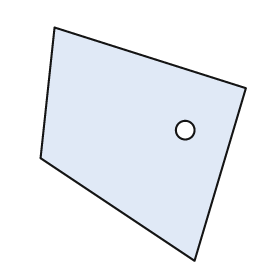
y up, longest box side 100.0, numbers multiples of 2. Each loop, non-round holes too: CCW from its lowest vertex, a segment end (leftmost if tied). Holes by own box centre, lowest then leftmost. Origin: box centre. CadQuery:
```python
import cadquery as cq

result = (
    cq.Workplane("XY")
    .moveTo(22.0, -50.0)
    .lineTo(44.0, 24.0)
    .lineTo(-38.0, 50.0)
    .lineTo(-44.0, -6.0)
    .close()
    .moveTo(18.0, 6.0)
    .circle(4.0)
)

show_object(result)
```